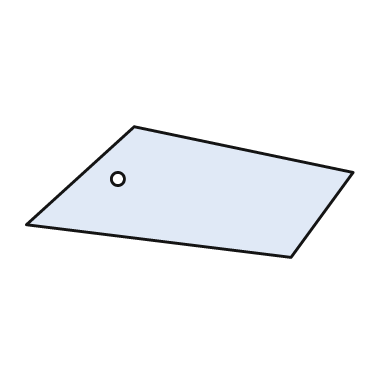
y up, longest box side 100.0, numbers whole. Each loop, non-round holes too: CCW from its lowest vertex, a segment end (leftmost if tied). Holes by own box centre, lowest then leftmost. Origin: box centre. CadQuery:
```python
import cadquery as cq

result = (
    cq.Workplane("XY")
    .moveTo(31.0, -20.0)
    .lineTo(50.0, 6.0)
    .lineTo(-17.0, 20.0)
    .lineTo(-50.0, -10.0)
    .close()
    .moveTo(-22.0, 4.0)
    .circle(2.0)
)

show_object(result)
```